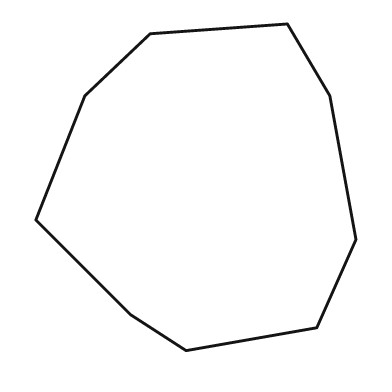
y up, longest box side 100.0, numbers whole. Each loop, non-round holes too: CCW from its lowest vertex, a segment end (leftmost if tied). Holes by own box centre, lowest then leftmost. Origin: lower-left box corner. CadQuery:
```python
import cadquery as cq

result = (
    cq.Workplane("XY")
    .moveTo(46.0, 0.0)
    .lineTo(86.0, 7.0)
    .lineTo(98.0, 34.0)
    .lineTo(90.0, 78.0)
    .lineTo(77.0, 100.0)
    .lineTo(35.0, 97.0)
    .lineTo(15.0, 78.0)
    .lineTo(0.0, 40.0)
    .lineTo(29.0, 11.0)
    .close()
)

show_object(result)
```